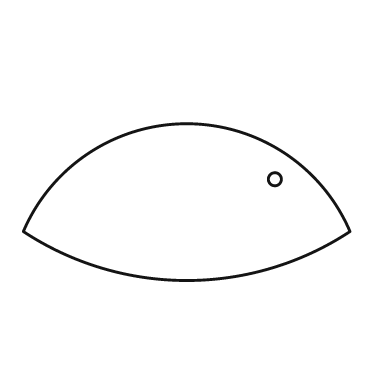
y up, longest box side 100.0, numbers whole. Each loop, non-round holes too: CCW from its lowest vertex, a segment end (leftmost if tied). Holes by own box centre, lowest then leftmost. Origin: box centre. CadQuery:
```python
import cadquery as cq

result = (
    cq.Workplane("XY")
    .moveTo(-50.0, -9.0)
    .threePointArc((0.0, -24.0), (50.0, -9.0))
    .threePointArc((0.0, 24.0), (-50.0, -9.0))
    .close()
    .moveTo(27.0, 7.0)
    .circle(2.0)
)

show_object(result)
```